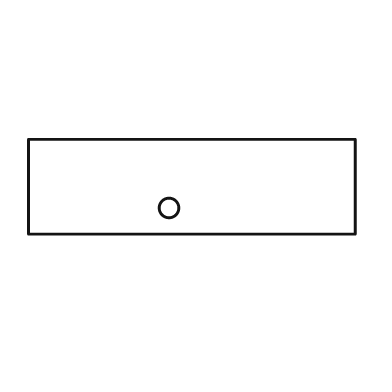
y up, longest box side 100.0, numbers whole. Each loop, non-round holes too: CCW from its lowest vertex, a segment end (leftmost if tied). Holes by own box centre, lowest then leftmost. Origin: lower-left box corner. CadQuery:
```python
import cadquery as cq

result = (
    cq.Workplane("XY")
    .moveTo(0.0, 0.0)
    .lineTo(100.0, 0.0)
    .lineTo(100.0, 29.0)
    .lineTo(0.0, 29.0)
    .close()
    .moveTo(43.0, 8.0)
    .circle(3.0)
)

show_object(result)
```